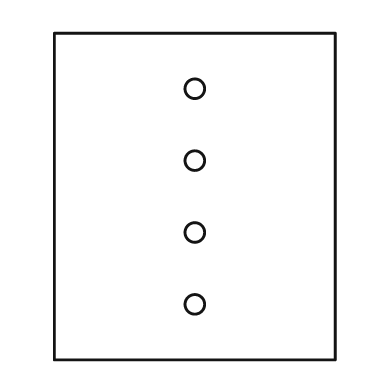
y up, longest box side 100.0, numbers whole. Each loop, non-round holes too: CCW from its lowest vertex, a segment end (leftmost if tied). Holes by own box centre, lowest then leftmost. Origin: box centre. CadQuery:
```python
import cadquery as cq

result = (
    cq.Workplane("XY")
    .moveTo(-43.0, -50.0)
    .lineTo(43.0, -50.0)
    .lineTo(43.0, 50.0)
    .lineTo(-43.0, 50.0)
    .close()
    .moveTo(0.0, -33.0)
    .circle(3.0)
    .moveTo(0.0, -11.0)
    .circle(3.0)
    .moveTo(0.0, 11.0)
    .circle(3.0)
    .moveTo(0.0, 33.0)
    .circle(3.0)
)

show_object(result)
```